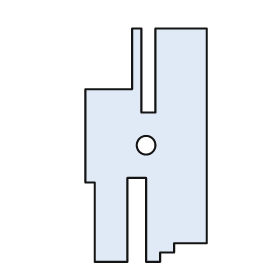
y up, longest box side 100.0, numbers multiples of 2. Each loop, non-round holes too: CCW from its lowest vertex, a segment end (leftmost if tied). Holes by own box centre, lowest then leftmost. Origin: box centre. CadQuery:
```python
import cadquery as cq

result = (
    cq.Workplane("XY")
    .moveTo(-22.0, -50.0)
    .lineTo(-8.0, -50.0)
    .lineTo(-8.0, -14.0)
    .lineTo(0.0, -14.0)
    .lineTo(0.0, -50.0)
    .lineTo(6.0, -50.0)
    .lineTo(6.0, -46.0)
    .lineTo(12.0, -46.0)
    .lineTo(12.0, -42.0)
    .lineTo(26.0, -42.0)
    .lineTo(26.0, 50.0)
    .lineTo(4.0, 50.0)
    .lineTo(4.0, 14.0)
    .lineTo(-2.0, 14.0)
    .lineTo(-2.0, 50.0)
    .lineTo(-6.0, 50.0)
    .lineTo(-6.0, 24.0)
    .lineTo(-26.0, 24.0)
    .lineTo(-26.0, -16.0)
    .lineTo(-22.0, -16.0)
    .close()
    .moveTo(0.0, 0.0)
    .circle(4.0)
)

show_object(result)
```